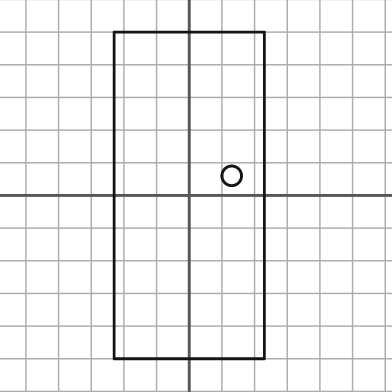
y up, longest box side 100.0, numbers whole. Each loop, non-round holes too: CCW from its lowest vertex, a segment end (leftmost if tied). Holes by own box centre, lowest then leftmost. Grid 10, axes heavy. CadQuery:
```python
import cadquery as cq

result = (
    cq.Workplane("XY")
    .moveTo(-23.0, -50.0)
    .lineTo(23.0, -50.0)
    .lineTo(23.0, 50.0)
    .lineTo(-23.0, 50.0)
    .close()
    .moveTo(13.0, 6.0)
    .circle(3.0)
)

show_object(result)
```